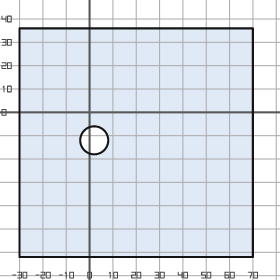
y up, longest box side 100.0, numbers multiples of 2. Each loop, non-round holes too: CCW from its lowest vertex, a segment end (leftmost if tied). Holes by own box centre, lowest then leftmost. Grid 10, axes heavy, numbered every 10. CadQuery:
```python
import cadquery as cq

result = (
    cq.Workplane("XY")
    .moveTo(-30.0, -62.0)
    .lineTo(70.0, -62.0)
    .lineTo(70.0, 36.0)
    .lineTo(-30.0, 36.0)
    .close()
    .moveTo(2.0, -12.0)
    .circle(6.0)
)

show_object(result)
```